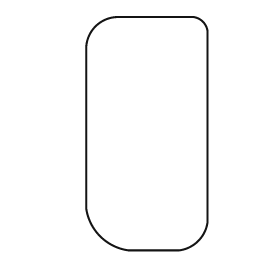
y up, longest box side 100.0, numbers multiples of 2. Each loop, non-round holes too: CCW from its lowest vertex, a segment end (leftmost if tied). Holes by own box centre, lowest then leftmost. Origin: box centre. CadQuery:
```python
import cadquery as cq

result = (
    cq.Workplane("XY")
    .moveTo(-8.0, -50.0)
    .lineTo(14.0, -50.0)
    .threePointArc((22.0, -46.0), (26.0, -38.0))
    .lineTo(26.0, 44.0)
    .threePointArc((24.0, 48.0), (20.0, 50.0))
    .lineTo(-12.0, 50.0)
    .threePointArc((-22.0, 46.0), (-26.0, 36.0))
    .lineTo(-26.0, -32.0)
    .threePointArc((-20.0, -44.0), (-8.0, -50.0))
    .close()
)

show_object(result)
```